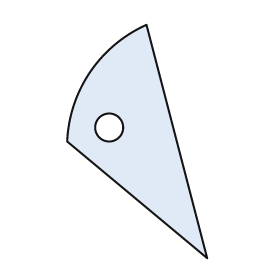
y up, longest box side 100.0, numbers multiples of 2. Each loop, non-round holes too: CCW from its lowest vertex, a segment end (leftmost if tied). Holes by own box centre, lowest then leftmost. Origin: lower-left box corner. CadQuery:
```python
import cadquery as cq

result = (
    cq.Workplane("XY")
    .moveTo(60.0, 0.0)
    .lineTo(34.0, 100.0)
    .threePointArc((10.0, 80.0), (0.0, 50.0))
    .close()
    .moveTo(18.0, 56.0)
    .circle(6.0)
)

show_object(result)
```